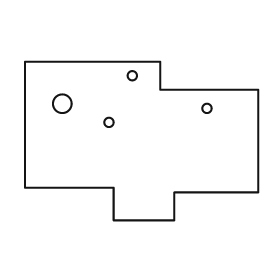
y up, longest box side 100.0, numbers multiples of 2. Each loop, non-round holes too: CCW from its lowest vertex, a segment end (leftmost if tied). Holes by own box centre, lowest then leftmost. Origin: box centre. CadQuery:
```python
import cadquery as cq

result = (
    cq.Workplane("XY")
    .moveTo(-12.0, -34.0)
    .lineTo(14.0, -34.0)
    .lineTo(14.0, -22.0)
    .lineTo(50.0, -22.0)
    .lineTo(50.0, 22.0)
    .lineTo(8.0, 22.0)
    .lineTo(8.0, 34.0)
    .lineTo(-50.0, 34.0)
    .lineTo(-50.0, -20.0)
    .lineTo(-12.0, -20.0)
    .close()
    .moveTo(-14.0, 8.0)
    .circle(2.0)
    .moveTo(28.0, 14.0)
    .circle(2.0)
    .moveTo(-34.0, 16.0)
    .circle(4.0)
    .moveTo(-4.0, 28.0)
    .circle(2.0)
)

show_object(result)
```